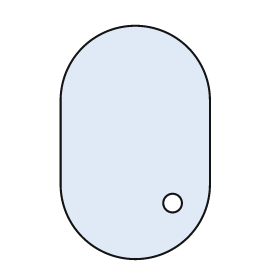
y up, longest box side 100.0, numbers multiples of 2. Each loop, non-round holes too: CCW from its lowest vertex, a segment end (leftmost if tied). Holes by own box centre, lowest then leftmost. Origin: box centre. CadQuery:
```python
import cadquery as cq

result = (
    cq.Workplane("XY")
    .moveTo(-32.0, -18.0)
    .threePointArc((0.0, -50.0), (32.0, -18.0))
    .lineTo(32.0, 18.0)
    .threePointArc((0.0, 50.0), (-32.0, 18.0))
    .close()
    .moveTo(16.0, -26.0)
    .circle(4.0)
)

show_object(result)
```